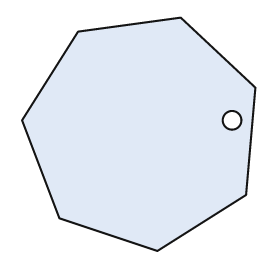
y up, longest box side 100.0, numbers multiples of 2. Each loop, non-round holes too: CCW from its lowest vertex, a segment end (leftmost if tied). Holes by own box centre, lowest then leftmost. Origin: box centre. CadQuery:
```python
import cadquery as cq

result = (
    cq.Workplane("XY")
    .moveTo(8.0, -50.0)
    .lineTo(46.0, -26.0)
    .lineTo(50.0, 20.0)
    .lineTo(18.0, 50.0)
    .lineTo(-26.0, 44.0)
    .lineTo(-50.0, 6.0)
    .lineTo(-34.0, -36.0)
    .close()
    .moveTo(40.0, 6.0)
    .circle(4.0)
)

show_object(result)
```